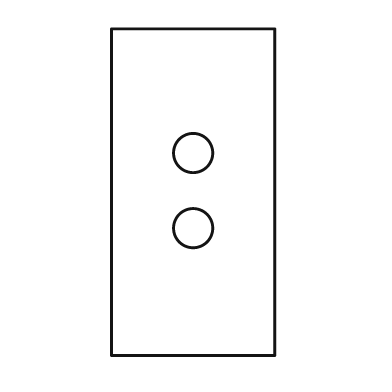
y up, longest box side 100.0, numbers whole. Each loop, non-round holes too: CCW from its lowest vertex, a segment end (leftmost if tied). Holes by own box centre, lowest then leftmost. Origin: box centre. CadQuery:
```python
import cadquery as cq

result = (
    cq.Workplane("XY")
    .moveTo(-25.0, -50.0)
    .lineTo(25.0, -50.0)
    .lineTo(25.0, 50.0)
    .lineTo(-25.0, 50.0)
    .close()
    .moveTo(0.0, -11.0)
    .circle(6.0)
    .moveTo(0.0, 12.0)
    .circle(6.0)
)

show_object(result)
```